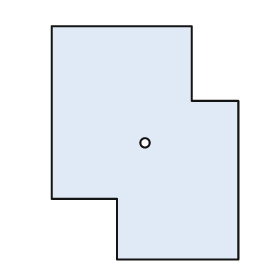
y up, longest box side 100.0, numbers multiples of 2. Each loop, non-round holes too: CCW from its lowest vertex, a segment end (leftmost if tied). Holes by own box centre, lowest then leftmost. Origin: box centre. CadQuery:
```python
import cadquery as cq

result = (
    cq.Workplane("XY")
    .moveTo(-12.0, -50.0)
    .lineTo(40.0, -50.0)
    .lineTo(40.0, 18.0)
    .lineTo(20.0, 18.0)
    .lineTo(20.0, 50.0)
    .lineTo(-40.0, 50.0)
    .lineTo(-40.0, -24.0)
    .lineTo(-12.0, -24.0)
    .close()
    .moveTo(0.0, 0.0)
    .circle(2.0)
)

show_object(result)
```